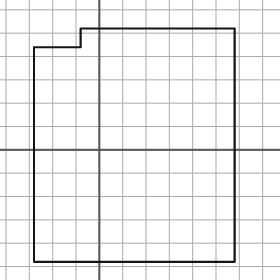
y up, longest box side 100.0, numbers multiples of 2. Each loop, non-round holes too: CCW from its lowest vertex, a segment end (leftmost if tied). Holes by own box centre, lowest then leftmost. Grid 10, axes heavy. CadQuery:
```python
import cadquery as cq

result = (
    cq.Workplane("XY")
    .moveTo(-28.0, -48.0)
    .lineTo(58.0, -48.0)
    .lineTo(58.0, 52.0)
    .lineTo(-8.0, 52.0)
    .lineTo(-8.0, 44.0)
    .lineTo(-28.0, 44.0)
    .close()
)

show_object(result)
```